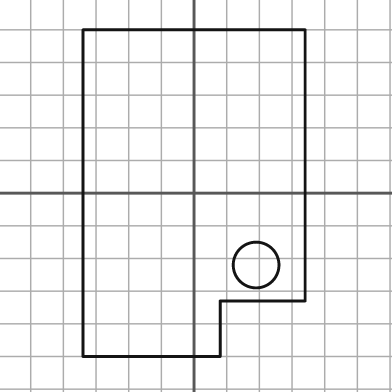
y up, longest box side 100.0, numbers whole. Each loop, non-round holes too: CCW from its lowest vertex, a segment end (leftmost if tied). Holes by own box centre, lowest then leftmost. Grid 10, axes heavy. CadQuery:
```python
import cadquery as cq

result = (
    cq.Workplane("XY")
    .moveTo(-34.0, -50.0)
    .lineTo(8.0, -50.0)
    .lineTo(8.0, -33.0)
    .lineTo(34.0, -33.0)
    .lineTo(34.0, 50.0)
    .lineTo(-34.0, 50.0)
    .close()
    .moveTo(19.0, -22.0)
    .circle(7.0)
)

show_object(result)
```